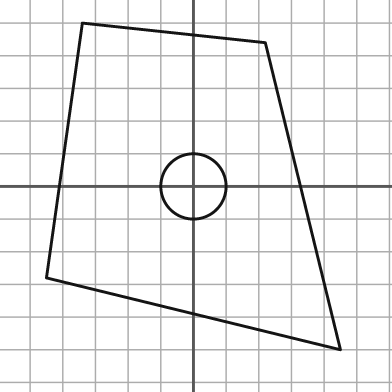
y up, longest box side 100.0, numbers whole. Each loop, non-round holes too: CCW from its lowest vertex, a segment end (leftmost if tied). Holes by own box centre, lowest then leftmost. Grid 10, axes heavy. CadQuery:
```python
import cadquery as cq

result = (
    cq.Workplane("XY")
    .moveTo(45.0, -50.0)
    .lineTo(22.0, 44.0)
    .lineTo(-34.0, 50.0)
    .lineTo(-45.0, -28.0)
    .close()
    .moveTo(0.0, 0.0)
    .circle(10.0)
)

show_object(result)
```